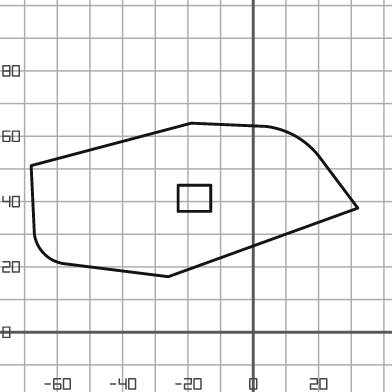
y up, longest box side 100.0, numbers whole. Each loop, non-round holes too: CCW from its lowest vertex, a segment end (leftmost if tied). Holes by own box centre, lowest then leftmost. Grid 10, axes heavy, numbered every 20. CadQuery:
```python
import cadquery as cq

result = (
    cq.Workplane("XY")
    .moveTo(-26.0, 17.0)
    .lineTo(32.0, 38.0)
    .lineTo(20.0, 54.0)
    .threePointArc((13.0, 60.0), (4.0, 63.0))
    .lineTo(-19.0, 64.0)
    .lineTo(-68.0, 51.0)
    .lineTo(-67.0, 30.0)
    .threePointArc((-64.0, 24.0), (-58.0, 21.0))
    .close()
    .moveTo(-23.0, 37.0)
    .lineTo(-13.0, 37.0)
    .lineTo(-13.0, 45.0)
    .lineTo(-23.0, 45.0)
    .close()
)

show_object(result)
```